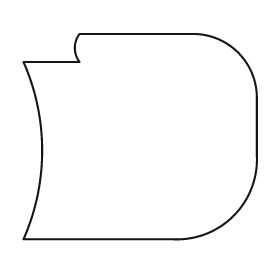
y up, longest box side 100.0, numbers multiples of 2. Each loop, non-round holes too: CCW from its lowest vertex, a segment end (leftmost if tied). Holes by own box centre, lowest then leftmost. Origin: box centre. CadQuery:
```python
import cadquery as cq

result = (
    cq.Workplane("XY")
    .moveTo(-50.0, -44.0)
    .lineTo(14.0, -44.0)
    .threePointArc((40.0, -34.0), (50.0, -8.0))
    .lineTo(50.0, 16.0)
    .threePointArc((42.0, 36.0), (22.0, 44.0))
    .lineTo(-26.0, 44.0)
    .threePointArc((-28.0, 38.0), (-26.0, 32.0))
    .lineTo(-50.0, 32.0)
    .threePointArc((-42.0, -6.0), (-50.0, -44.0))
    .close()
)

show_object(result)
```